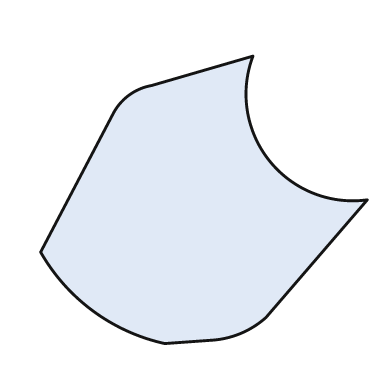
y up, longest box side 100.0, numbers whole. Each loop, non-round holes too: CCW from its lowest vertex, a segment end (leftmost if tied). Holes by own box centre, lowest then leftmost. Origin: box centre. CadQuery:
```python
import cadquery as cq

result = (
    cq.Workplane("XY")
    .moveTo(-12.0, -44.0)
    .lineTo(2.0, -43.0)
    .threePointArc((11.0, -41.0), (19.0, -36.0))
    .lineTo(50.0, 0.0)
    .threePointArc((20.0, 12.0), (15.0, 44.0))
    .lineTo(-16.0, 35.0)
    .threePointArc((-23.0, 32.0), (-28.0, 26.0))
    .lineTo(-50.0, -16.0)
    .threePointArc((-34.0, -34.0), (-12.0, -44.0))
    .close()
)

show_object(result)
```